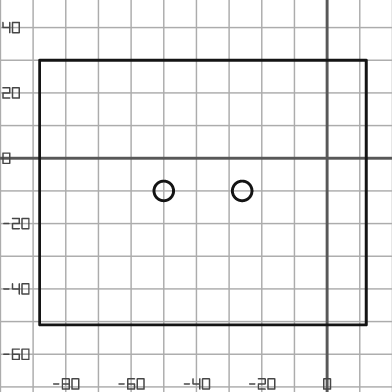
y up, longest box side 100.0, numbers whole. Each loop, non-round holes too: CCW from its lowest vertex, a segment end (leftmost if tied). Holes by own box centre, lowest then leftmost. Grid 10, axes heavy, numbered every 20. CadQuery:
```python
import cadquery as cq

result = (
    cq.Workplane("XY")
    .moveTo(-88.0, -51.0)
    .lineTo(12.0, -51.0)
    .lineTo(12.0, 30.0)
    .lineTo(-88.0, 30.0)
    .close()
    .moveTo(-50.0, -10.0)
    .circle(3.0)
    .moveTo(-26.0, -10.0)
    .circle(3.0)
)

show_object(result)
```